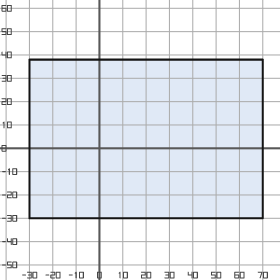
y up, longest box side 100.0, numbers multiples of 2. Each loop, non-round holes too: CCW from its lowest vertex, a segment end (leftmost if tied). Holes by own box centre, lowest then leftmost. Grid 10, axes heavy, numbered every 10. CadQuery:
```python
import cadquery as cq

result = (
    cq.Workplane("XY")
    .moveTo(-30.0, -30.0)
    .lineTo(70.0, -30.0)
    .lineTo(70.0, 38.0)
    .lineTo(-30.0, 38.0)
    .close()
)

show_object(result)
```